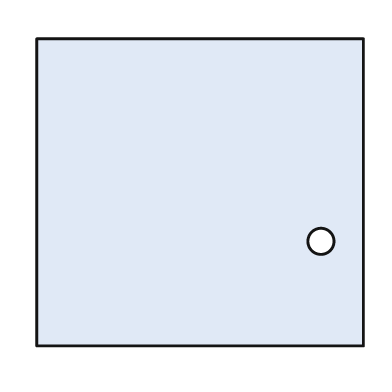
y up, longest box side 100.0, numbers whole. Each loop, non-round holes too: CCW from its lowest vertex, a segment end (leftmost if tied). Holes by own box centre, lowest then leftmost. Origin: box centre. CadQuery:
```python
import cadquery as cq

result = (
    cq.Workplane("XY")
    .moveTo(-50.0, -47.0)
    .lineTo(50.0, -47.0)
    .lineTo(50.0, 47.0)
    .lineTo(-50.0, 47.0)
    .close()
    .moveTo(37.0, -15.0)
    .circle(4.0)
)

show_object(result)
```